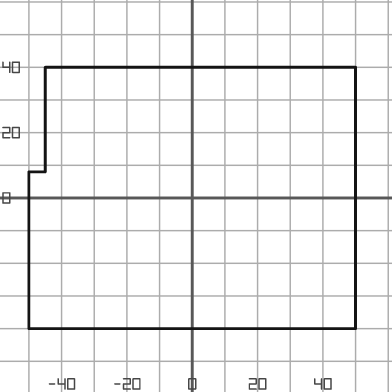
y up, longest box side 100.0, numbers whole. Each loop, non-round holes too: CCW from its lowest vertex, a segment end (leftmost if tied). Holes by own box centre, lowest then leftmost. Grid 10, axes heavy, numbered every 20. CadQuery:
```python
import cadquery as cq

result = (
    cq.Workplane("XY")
    .moveTo(-50.0, -40.0)
    .lineTo(50.0, -40.0)
    .lineTo(50.0, 40.0)
    .lineTo(-45.0, 40.0)
    .lineTo(-45.0, 8.0)
    .lineTo(-50.0, 8.0)
    .close()
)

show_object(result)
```